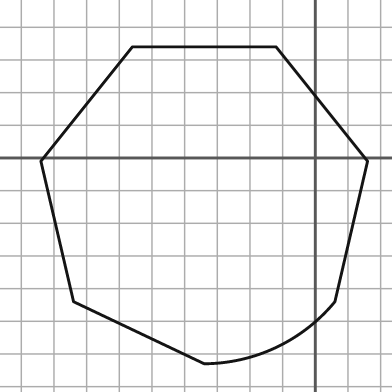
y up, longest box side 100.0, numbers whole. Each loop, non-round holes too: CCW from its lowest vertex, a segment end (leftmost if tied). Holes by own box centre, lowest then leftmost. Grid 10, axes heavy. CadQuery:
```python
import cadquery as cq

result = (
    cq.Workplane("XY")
    .moveTo(-34.0, -63.0)
    .threePointArc((-12.0, -58.0), (6.0, -44.0))
    .lineTo(16.0, -1.0)
    .lineTo(-12.0, 34.0)
    .lineTo(-56.0, 34.0)
    .lineTo(-84.0, -1.0)
    .lineTo(-74.0, -44.0)
    .close()
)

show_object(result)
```